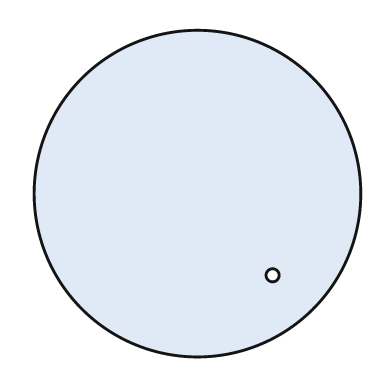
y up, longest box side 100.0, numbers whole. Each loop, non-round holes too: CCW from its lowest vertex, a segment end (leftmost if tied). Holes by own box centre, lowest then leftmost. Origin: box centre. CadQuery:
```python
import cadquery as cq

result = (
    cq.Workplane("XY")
    .moveTo(0.0, 0.0)
    .circle(50.0)
    .moveTo(23.0, -25.0)
    .circle(2.0)
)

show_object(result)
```